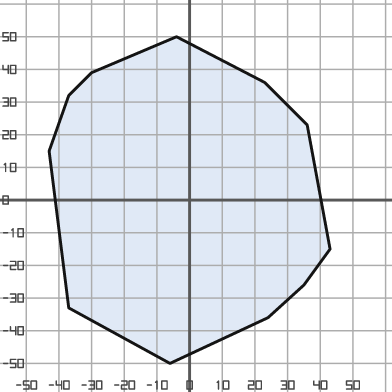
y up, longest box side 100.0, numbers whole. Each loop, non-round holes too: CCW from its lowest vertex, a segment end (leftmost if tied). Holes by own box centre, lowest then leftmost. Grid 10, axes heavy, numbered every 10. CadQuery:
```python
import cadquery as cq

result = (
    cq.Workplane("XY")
    .moveTo(-6.0, -50.0)
    .lineTo(24.0, -36.0)
    .lineTo(35.0, -26.0)
    .lineTo(43.0, -15.0)
    .lineTo(36.0, 23.0)
    .lineTo(23.0, 36.0)
    .lineTo(-4.0, 50.0)
    .lineTo(-30.0, 39.0)
    .lineTo(-37.0, 32.0)
    .lineTo(-43.0, 15.0)
    .lineTo(-37.0, -33.0)
    .close()
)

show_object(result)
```